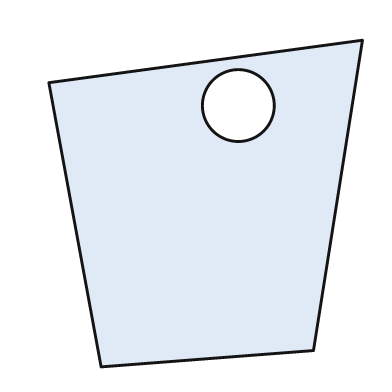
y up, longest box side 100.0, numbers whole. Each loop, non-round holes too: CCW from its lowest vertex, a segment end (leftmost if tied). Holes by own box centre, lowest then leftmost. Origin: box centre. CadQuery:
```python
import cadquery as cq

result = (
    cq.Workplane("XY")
    .moveTo(-32.0, -50.0)
    .lineTo(33.0, -45.0)
    .lineTo(48.0, 50.0)
    .lineTo(-48.0, 37.0)
    .close()
    .moveTo(10.0, 30.0)
    .circle(11.0)
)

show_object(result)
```